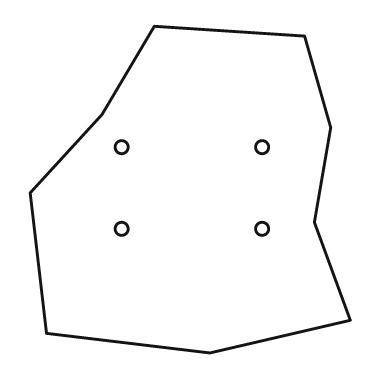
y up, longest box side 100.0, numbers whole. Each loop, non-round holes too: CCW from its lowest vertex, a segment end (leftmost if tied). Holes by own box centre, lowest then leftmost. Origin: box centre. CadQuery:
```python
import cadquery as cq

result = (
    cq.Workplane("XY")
    .moveTo(6.0, -50.0)
    .lineTo(49.0, -40.0)
    .lineTo(38.0, -10.0)
    .lineTo(43.0, 19.0)
    .lineTo(35.0, 47.0)
    .lineTo(-11.0, 50.0)
    .lineTo(-27.0, 23.0)
    .lineTo(-49.0, -1.0)
    .lineTo(-44.0, -44.0)
    .close()
    .moveTo(-21.0, -12.0)
    .circle(2.0)
    .moveTo(22.0, -12.0)
    .circle(2.0)
    .moveTo(-21.0, 13.0)
    .circle(2.0)
    .moveTo(22.0, 13.0)
    .circle(2.0)
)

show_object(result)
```